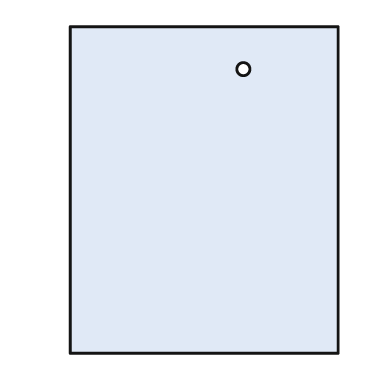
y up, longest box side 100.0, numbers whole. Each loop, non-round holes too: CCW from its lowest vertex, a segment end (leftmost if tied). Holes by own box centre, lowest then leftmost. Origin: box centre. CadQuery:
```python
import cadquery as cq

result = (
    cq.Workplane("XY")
    .moveTo(-41.0, -50.0)
    .lineTo(41.0, -50.0)
    .lineTo(41.0, 50.0)
    .lineTo(-41.0, 50.0)
    .close()
    .moveTo(12.0, 37.0)
    .circle(2.0)
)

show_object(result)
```